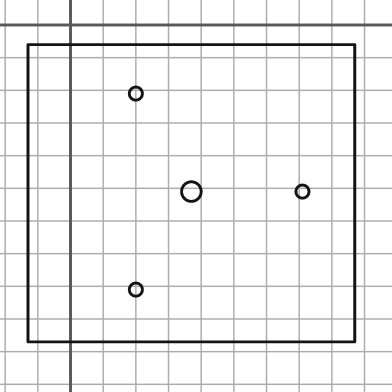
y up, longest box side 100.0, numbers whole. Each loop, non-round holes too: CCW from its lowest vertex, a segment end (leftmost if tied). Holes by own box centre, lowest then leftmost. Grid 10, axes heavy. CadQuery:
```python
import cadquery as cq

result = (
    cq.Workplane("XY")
    .moveTo(-13.0, -97.0)
    .lineTo(87.0, -97.0)
    .lineTo(87.0, -6.0)
    .lineTo(-13.0, -6.0)
    .close()
    .moveTo(20.0, -81.0)
    .circle(2.0)
    .moveTo(37.0, -51.0)
    .circle(3.0)
    .moveTo(71.0, -51.0)
    .circle(2.0)
    .moveTo(20.0, -21.0)
    .circle(2.0)
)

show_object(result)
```